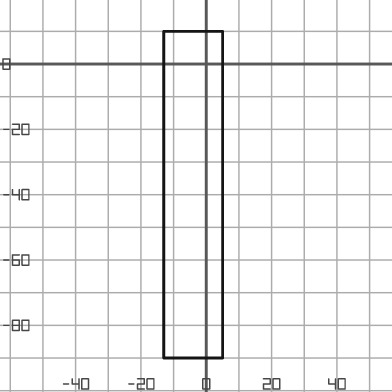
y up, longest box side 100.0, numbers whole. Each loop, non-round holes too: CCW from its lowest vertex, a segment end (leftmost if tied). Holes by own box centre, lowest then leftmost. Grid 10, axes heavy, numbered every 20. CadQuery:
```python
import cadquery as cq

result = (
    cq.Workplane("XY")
    .moveTo(-13.0, -90.0)
    .lineTo(5.0, -90.0)
    .lineTo(5.0, 10.0)
    .lineTo(-13.0, 10.0)
    .close()
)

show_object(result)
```